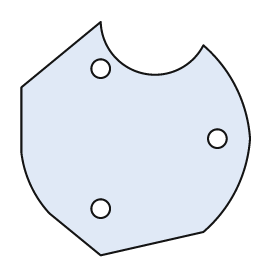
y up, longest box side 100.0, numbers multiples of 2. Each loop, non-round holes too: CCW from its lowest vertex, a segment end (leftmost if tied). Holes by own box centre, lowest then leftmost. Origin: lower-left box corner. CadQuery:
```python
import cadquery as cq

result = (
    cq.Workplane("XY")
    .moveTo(34.0, 0.0)
    .lineTo(78.0, 10.0)
    .threePointArc((92.0, 28.0), (98.0, 50.0))
    .threePointArc((92.0, 72.0), (78.0, 90.0))
    .threePointArc((52.0, 78.0), (34.0, 100.0))
    .lineTo(0.0, 72.0)
    .lineTo(0.0, 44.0)
    .threePointArc((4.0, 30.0), (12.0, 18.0))
    .close()
    .moveTo(34.0, 20.0)
    .circle(4.0)
    .moveTo(84.0, 50.0)
    .circle(4.0)
    .moveTo(34.0, 80.0)
    .circle(4.0)
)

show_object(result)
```